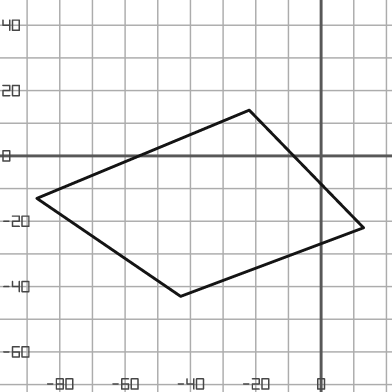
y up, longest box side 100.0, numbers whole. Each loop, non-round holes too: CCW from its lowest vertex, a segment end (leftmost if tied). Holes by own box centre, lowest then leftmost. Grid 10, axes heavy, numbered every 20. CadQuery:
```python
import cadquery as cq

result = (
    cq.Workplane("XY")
    .moveTo(-43.0, -43.0)
    .lineTo(13.0, -22.0)
    .lineTo(-22.0, 14.0)
    .lineTo(-87.0, -13.0)
    .close()
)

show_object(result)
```